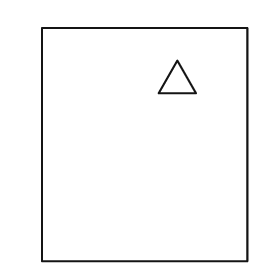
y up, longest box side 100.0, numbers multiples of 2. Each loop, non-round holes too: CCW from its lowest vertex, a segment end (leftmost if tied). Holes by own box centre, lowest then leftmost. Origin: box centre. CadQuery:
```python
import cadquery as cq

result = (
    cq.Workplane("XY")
    .moveTo(-44.0, -50.0)
    .lineTo(44.0, -50.0)
    .lineTo(44.0, 50.0)
    .lineTo(-44.0, 50.0)
    .close()
    .moveTo(6.0, 22.0)
    .lineTo(22.0, 22.0)
    .lineTo(14.0, 36.0)
    .close()
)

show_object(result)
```